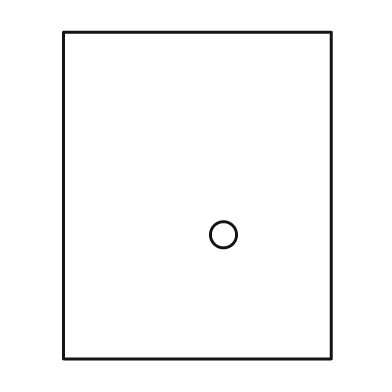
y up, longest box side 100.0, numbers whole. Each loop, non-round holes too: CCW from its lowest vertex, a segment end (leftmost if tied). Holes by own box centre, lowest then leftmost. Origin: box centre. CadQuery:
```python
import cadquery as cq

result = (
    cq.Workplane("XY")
    .moveTo(-41.0, -50.0)
    .lineTo(41.0, -50.0)
    .lineTo(41.0, 50.0)
    .lineTo(-41.0, 50.0)
    .close()
    .moveTo(8.0, -12.0)
    .circle(4.0)
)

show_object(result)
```